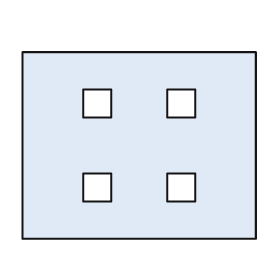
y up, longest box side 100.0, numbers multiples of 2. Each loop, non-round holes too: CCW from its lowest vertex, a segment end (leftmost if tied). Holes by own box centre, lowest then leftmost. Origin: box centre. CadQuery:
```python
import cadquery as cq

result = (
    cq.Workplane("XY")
    .moveTo(-50.0, -40.0)
    .lineTo(50.0, -40.0)
    .lineTo(50.0, 40.0)
    .lineTo(-50.0, 40.0)
    .close()
    .moveTo(-24.0, -24.0)
    .lineTo(-12.0, -24.0)
    .lineTo(-12.0, -12.0)
    .lineTo(-24.0, -12.0)
    .close()
    .moveTo(12.0, -24.0)
    .lineTo(24.0, -24.0)
    .lineTo(24.0, -12.0)
    .lineTo(12.0, -12.0)
    .close()
    .moveTo(-24.0, 12.0)
    .lineTo(-12.0, 12.0)
    .lineTo(-12.0, 24.0)
    .lineTo(-24.0, 24.0)
    .close()
    .moveTo(12.0, 12.0)
    .lineTo(24.0, 12.0)
    .lineTo(24.0, 24.0)
    .lineTo(12.0, 24.0)
    .close()
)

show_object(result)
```